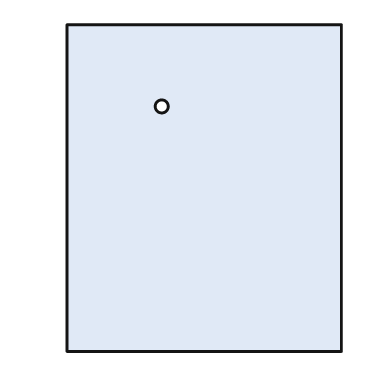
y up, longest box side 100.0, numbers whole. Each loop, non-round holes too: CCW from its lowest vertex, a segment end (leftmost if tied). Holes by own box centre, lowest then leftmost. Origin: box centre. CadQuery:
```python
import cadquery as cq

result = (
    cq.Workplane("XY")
    .moveTo(-42.0, -50.0)
    .lineTo(42.0, -50.0)
    .lineTo(42.0, 50.0)
    .lineTo(-42.0, 50.0)
    .close()
    .moveTo(-13.0, 25.0)
    .circle(2.0)
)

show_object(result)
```